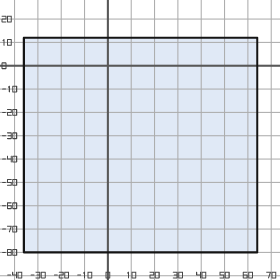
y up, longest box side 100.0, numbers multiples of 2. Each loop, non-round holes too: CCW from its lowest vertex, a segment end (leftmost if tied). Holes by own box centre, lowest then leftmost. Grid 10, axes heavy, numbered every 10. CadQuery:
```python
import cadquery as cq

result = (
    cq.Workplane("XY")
    .moveTo(-36.0, -80.0)
    .lineTo(64.0, -80.0)
    .lineTo(64.0, 12.0)
    .lineTo(-36.0, 12.0)
    .close()
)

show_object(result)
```